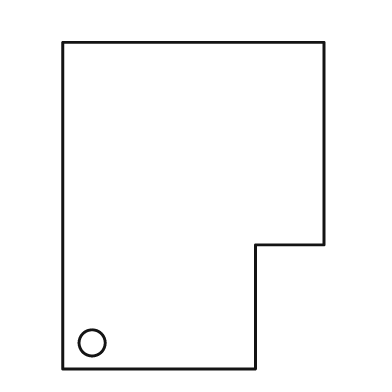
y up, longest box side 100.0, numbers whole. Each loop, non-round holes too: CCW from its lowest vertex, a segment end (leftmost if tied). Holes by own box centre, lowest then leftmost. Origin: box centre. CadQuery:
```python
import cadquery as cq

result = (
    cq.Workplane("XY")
    .moveTo(-40.0, -50.0)
    .lineTo(19.0, -50.0)
    .lineTo(19.0, -12.0)
    .lineTo(40.0, -12.0)
    .lineTo(40.0, 50.0)
    .lineTo(-40.0, 50.0)
    .close()
    .moveTo(-31.0, -42.0)
    .circle(4.0)
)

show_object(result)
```